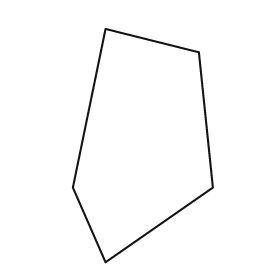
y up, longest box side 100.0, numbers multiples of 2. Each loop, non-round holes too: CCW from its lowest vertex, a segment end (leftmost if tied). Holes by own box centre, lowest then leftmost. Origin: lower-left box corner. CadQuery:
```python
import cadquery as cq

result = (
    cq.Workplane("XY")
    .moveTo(14.0, 0.0)
    .lineTo(60.0, 32.0)
    .lineTo(54.0, 90.0)
    .lineTo(14.0, 100.0)
    .lineTo(0.0, 32.0)
    .close()
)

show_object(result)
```